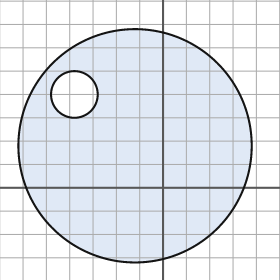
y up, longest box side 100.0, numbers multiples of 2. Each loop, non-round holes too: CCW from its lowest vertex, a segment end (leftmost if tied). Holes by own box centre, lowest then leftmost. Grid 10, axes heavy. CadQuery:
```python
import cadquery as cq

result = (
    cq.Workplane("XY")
    .moveTo(-12.0, 18.0)
    .circle(50.0)
    .moveTo(-38.0, 40.0)
    .circle(10.0)
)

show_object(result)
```